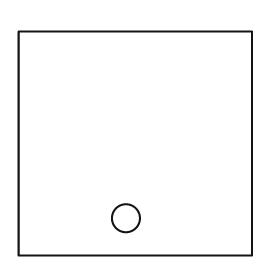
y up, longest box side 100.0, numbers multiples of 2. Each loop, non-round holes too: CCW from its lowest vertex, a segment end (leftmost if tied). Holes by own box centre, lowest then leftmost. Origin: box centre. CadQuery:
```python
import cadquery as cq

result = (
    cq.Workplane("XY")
    .moveTo(-50.0, -48.0)
    .lineTo(50.0, -48.0)
    .lineTo(50.0, 48.0)
    .lineTo(-50.0, 48.0)
    .close()
    .moveTo(-4.0, -32.0)
    .circle(6.0)
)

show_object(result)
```